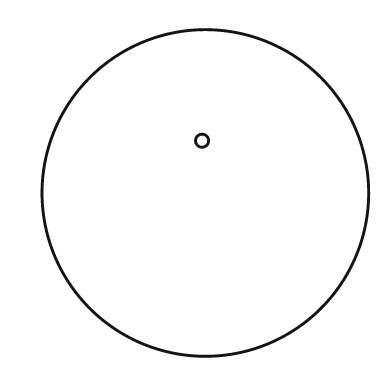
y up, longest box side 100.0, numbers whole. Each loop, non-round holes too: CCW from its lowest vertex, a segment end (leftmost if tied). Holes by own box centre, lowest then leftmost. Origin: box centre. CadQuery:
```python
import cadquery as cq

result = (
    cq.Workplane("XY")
    .moveTo(0.0, 0.0)
    .circle(50.0)
    .moveTo(-1.0, 16.0)
    .circle(2.0)
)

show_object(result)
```